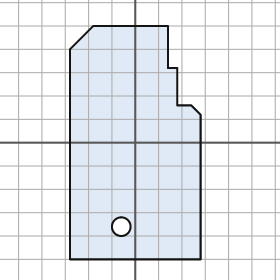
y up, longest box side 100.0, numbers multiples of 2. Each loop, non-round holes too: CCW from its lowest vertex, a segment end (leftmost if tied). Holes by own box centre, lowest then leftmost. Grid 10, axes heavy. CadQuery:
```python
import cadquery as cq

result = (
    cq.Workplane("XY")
    .moveTo(-28.0, -50.0)
    .lineTo(28.0, -50.0)
    .lineTo(28.0, 12.0)
    .lineTo(24.0, 16.0)
    .lineTo(18.0, 16.0)
    .lineTo(18.0, 32.0)
    .lineTo(14.0, 32.0)
    .lineTo(14.0, 50.0)
    .lineTo(-18.0, 50.0)
    .lineTo(-28.0, 40.0)
    .close()
    .moveTo(-6.0, -36.0)
    .circle(4.0)
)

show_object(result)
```